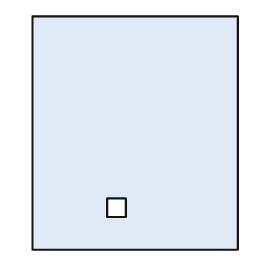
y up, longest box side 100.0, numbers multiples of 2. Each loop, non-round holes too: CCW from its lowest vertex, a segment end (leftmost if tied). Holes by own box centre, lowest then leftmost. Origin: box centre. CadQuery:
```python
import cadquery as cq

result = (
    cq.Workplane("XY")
    .moveTo(-44.0, -50.0)
    .lineTo(44.0, -50.0)
    .lineTo(44.0, 50.0)
    .lineTo(-44.0, 50.0)
    .close()
    .moveTo(-12.0, -36.0)
    .lineTo(-4.0, -36.0)
    .lineTo(-4.0, -28.0)
    .lineTo(-12.0, -28.0)
    .close()
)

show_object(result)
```